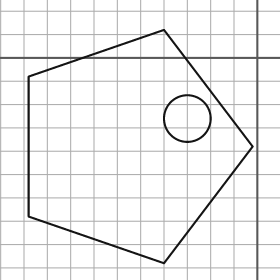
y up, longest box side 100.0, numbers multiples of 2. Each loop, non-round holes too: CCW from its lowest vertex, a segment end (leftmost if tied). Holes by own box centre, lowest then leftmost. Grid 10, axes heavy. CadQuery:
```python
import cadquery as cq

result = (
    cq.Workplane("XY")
    .moveTo(-40.0, -88.0)
    .lineTo(-2.0, -38.0)
    .lineTo(-40.0, 12.0)
    .lineTo(-98.0, -8.0)
    .lineTo(-98.0, -68.0)
    .close()
    .moveTo(-30.0, -26.0)
    .circle(10.0)
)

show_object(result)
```